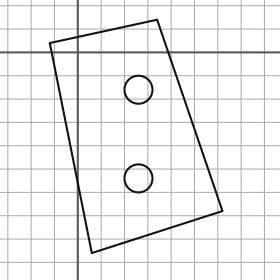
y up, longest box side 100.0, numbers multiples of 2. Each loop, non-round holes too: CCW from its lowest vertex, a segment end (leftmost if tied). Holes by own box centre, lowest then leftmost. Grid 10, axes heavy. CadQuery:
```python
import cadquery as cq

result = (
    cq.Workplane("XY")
    .moveTo(6.0, -86.0)
    .lineTo(62.0, -68.0)
    .lineTo(34.0, 14.0)
    .lineTo(-12.0, 4.0)
    .close()
    .moveTo(26.0, -54.0)
    .circle(6.0)
    .moveTo(26.0, -16.0)
    .circle(6.0)
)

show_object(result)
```